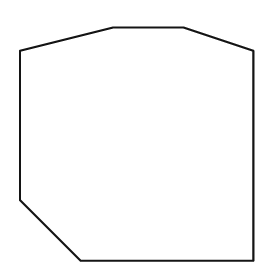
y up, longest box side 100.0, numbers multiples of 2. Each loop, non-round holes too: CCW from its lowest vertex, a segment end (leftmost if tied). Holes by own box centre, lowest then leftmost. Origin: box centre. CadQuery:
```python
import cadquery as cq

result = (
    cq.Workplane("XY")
    .moveTo(-24.0, -50.0)
    .lineTo(50.0, -50.0)
    .lineTo(50.0, 40.0)
    .lineTo(20.0, 50.0)
    .lineTo(-10.0, 50.0)
    .lineTo(-50.0, 40.0)
    .lineTo(-50.0, -24.0)
    .close()
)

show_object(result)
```